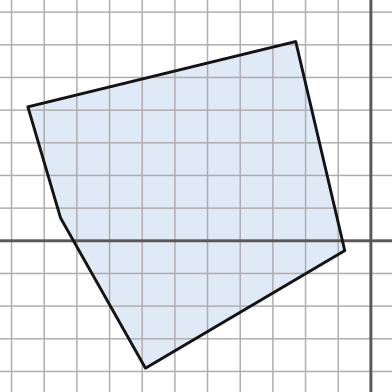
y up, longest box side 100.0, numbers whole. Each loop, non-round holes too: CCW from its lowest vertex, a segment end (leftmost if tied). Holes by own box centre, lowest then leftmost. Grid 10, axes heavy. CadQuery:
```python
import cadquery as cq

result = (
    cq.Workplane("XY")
    .moveTo(-69.0, -39.0)
    .lineTo(-8.0, -3.0)
    .lineTo(-23.0, 61.0)
    .lineTo(-105.0, 41.0)
    .lineTo(-95.0, 7.0)
    .close()
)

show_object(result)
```